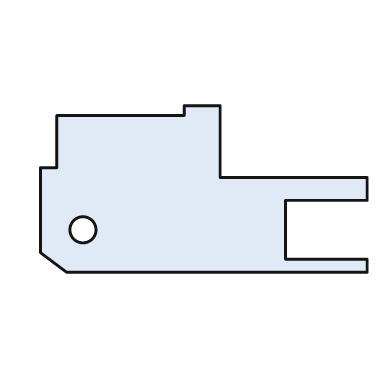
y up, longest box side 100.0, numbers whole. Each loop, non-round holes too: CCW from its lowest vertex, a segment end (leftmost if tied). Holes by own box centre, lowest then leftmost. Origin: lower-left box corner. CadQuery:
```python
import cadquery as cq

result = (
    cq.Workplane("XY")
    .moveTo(8.0, 0.0)
    .lineTo(100.0, 0.0)
    .lineTo(100.0, 4.0)
    .lineTo(75.0, 4.0)
    .lineTo(75.0, 22.0)
    .lineTo(100.0, 22.0)
    .lineTo(100.0, 29.0)
    .lineTo(55.0, 29.0)
    .lineTo(55.0, 51.0)
    .lineTo(44.0, 51.0)
    .lineTo(44.0, 48.0)
    .lineTo(5.0, 48.0)
    .lineTo(5.0, 32.0)
    .lineTo(0.0, 32.0)
    .lineTo(0.0, 6.0)
    .close()
    .moveTo(13.0, 13.0)
    .circle(4.0)
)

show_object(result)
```